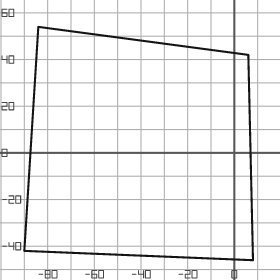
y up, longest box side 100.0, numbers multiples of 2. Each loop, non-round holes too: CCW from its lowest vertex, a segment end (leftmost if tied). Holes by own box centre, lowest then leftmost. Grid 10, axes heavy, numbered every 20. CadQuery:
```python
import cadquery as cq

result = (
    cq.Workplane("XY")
    .moveTo(8.0, -46.0)
    .lineTo(6.0, 42.0)
    .lineTo(-84.0, 54.0)
    .lineTo(-90.0, -42.0)
    .close()
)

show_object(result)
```